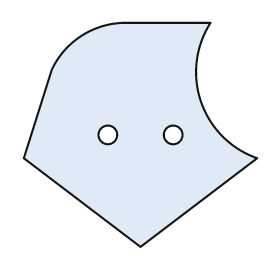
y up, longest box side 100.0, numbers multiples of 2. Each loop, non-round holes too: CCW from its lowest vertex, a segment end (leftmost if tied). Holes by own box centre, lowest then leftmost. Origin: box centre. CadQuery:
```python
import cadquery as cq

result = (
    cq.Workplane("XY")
    .moveTo(0.0, -48.0)
    .lineTo(50.0, -10.0)
    .threePointArc((26.0, 14.0), (30.0, 48.0))
    .lineTo(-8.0, 48.0)
    .threePointArc((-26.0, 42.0), (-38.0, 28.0))
    .lineTo(-50.0, -10.0)
    .close()
    .moveTo(-14.0, 0.0)
    .circle(4.0)
    .moveTo(14.0, 0.0)
    .circle(4.0)
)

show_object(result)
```